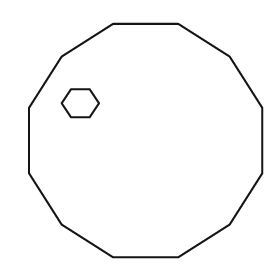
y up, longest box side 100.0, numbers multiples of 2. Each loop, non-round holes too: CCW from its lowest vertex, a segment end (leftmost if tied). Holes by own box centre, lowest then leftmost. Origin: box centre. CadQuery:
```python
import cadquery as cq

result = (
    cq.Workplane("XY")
    .moveTo(-14.0, -50.0)
    .lineTo(14.0, -50.0)
    .lineTo(36.0, -36.0)
    .lineTo(50.0, -14.0)
    .lineTo(50.0, 14.0)
    .lineTo(36.0, 36.0)
    .lineTo(14.0, 50.0)
    .lineTo(-14.0, 50.0)
    .lineTo(-36.0, 36.0)
    .lineTo(-50.0, 14.0)
    .lineTo(-50.0, -14.0)
    .lineTo(-36.0, -36.0)
    .close()
    .moveTo(-32.0, 10.0)
    .lineTo(-24.0, 10.0)
    .lineTo(-20.0, 16.0)
    .lineTo(-24.0, 22.0)
    .lineTo(-32.0, 22.0)
    .lineTo(-36.0, 16.0)
    .close()
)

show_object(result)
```